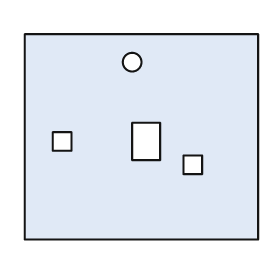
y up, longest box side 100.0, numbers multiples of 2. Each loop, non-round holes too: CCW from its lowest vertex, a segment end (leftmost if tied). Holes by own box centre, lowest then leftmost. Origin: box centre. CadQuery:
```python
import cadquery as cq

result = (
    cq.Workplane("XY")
    .moveTo(-50.0, -44.0)
    .lineTo(50.0, -44.0)
    .lineTo(50.0, 44.0)
    .lineTo(-50.0, 44.0)
    .close()
    .moveTo(18.0, -16.0)
    .lineTo(26.0, -16.0)
    .lineTo(26.0, -8.0)
    .lineTo(18.0, -8.0)
    .close()
    .moveTo(-38.0, -6.0)
    .lineTo(-30.0, -6.0)
    .lineTo(-30.0, 2.0)
    .lineTo(-38.0, 2.0)
    .close()
    .moveTo(-4.0, -10.0)
    .lineTo(8.0, -10.0)
    .lineTo(8.0, 6.0)
    .lineTo(-4.0, 6.0)
    .close()
    .moveTo(-4.0, 32.0)
    .circle(4.0)
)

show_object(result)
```